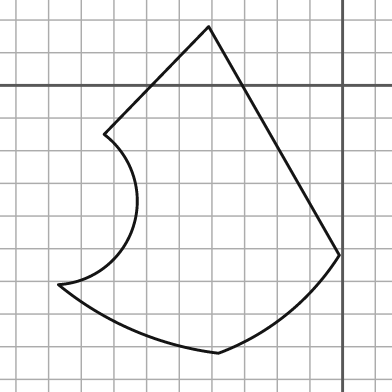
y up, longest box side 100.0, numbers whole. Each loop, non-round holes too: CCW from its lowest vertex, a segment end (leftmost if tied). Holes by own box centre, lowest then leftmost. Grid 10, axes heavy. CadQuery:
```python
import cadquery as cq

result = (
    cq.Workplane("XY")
    .moveTo(-38.0, -82.0)
    .threePointArc((-17.0, -70.0), (-1.0, -52.0))
    .lineTo(-41.0, 18.0)
    .lineTo(-73.0, -15.0)
    .threePointArc((-64.0, -43.0), (-87.0, -61.0))
    .threePointArc((-64.0, -75.0), (-38.0, -82.0))
    .close()
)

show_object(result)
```